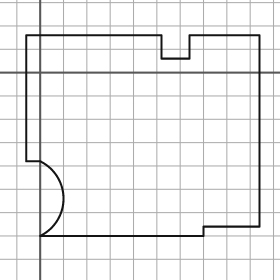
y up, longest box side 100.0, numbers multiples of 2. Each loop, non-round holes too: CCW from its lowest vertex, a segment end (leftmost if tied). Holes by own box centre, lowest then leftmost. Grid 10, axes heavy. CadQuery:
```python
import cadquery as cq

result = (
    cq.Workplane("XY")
    .moveTo(0.0, -70.0)
    .lineTo(70.0, -70.0)
    .lineTo(70.0, -66.0)
    .lineTo(94.0, -66.0)
    .lineTo(94.0, 16.0)
    .lineTo(64.0, 16.0)
    .lineTo(64.0, 6.0)
    .lineTo(52.0, 6.0)
    .lineTo(52.0, 16.0)
    .lineTo(-6.0, 16.0)
    .lineTo(-6.0, -38.0)
    .lineTo(0.0, -38.0)
    .threePointArc((10.0, -54.0), (0.0, -70.0))
    .close()
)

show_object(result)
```